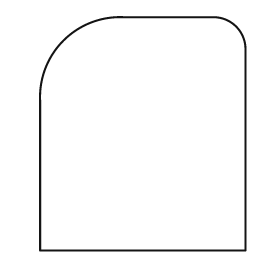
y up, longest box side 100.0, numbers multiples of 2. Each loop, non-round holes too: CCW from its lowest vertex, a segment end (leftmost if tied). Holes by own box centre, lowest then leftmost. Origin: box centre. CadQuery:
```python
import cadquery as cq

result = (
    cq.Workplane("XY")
    .moveTo(-44.0, -50.0)
    .lineTo(44.0, -50.0)
    .lineTo(44.0, 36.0)
    .threePointArc((40.0, 46.0), (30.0, 50.0))
    .lineTo(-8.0, 50.0)
    .threePointArc((-34.0, 40.0), (-44.0, 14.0))
    .close()
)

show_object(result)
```